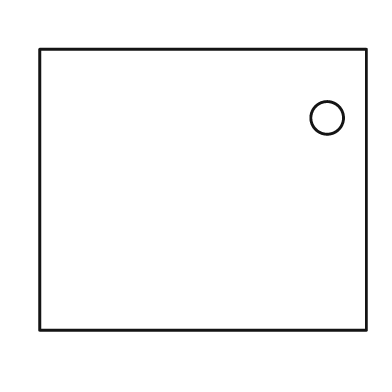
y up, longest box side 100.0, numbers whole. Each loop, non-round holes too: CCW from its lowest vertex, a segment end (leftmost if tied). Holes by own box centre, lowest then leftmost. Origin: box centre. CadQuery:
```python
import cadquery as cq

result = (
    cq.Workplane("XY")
    .moveTo(-50.0, -43.0)
    .lineTo(50.0, -43.0)
    .lineTo(50.0, 43.0)
    .lineTo(-50.0, 43.0)
    .close()
    .moveTo(38.0, 22.0)
    .circle(5.0)
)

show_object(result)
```